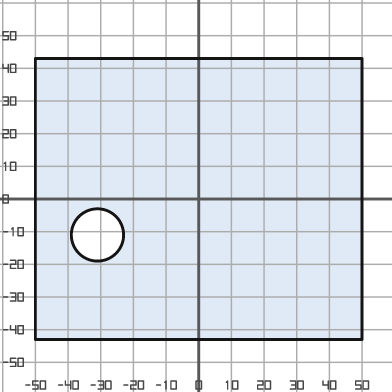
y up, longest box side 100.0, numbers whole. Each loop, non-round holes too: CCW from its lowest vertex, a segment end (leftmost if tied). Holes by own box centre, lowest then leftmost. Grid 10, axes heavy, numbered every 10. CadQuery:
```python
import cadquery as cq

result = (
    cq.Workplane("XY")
    .moveTo(-50.0, -43.0)
    .lineTo(50.0, -43.0)
    .lineTo(50.0, 43.0)
    .lineTo(-50.0, 43.0)
    .close()
    .moveTo(-31.0, -11.0)
    .circle(8.0)
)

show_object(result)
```